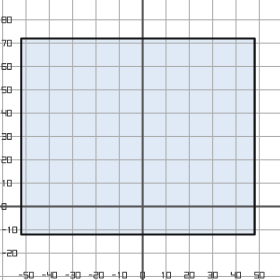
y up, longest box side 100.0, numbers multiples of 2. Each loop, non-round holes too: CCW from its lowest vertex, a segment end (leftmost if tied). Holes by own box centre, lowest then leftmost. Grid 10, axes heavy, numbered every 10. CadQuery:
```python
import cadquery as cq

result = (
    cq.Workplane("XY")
    .moveTo(-52.0, -12.0)
    .lineTo(48.0, -12.0)
    .lineTo(48.0, 72.0)
    .lineTo(-52.0, 72.0)
    .close()
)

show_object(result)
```